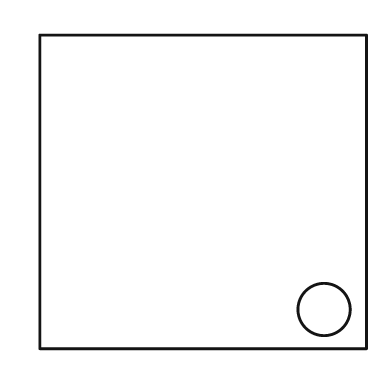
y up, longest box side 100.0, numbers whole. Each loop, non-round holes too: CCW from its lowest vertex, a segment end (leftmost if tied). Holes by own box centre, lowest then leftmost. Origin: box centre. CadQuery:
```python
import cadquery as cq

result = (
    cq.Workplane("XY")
    .moveTo(-50.0, -48.0)
    .lineTo(50.0, -48.0)
    .lineTo(50.0, 48.0)
    .lineTo(-50.0, 48.0)
    .close()
    .moveTo(37.0, -36.0)
    .circle(8.0)
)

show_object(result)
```